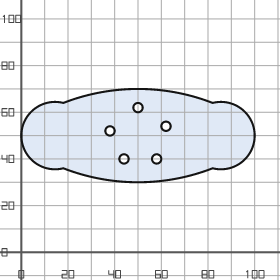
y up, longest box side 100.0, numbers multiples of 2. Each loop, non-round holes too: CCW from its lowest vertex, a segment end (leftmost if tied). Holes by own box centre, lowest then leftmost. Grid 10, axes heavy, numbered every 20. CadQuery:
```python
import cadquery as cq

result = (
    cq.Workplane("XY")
    .moveTo(18.0, 36.0)
    .threePointArc((50.0, 30.0), (82.0, 36.0))
    .threePointArc((100.0, 50.0), (82.0, 64.0))
    .threePointArc((50.0, 70.0), (18.0, 64.0))
    .threePointArc((0.0, 50.0), (18.0, 36.0))
    .close()
    .moveTo(44.0, 40.0)
    .circle(2.0)
    .moveTo(58.0, 40.0)
    .circle(2.0)
    .moveTo(38.0, 52.0)
    .circle(2.0)
    .moveTo(62.0, 54.0)
    .circle(2.0)
    .moveTo(50.0, 62.0)
    .circle(2.0)
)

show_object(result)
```